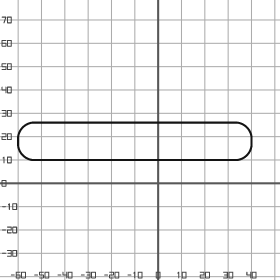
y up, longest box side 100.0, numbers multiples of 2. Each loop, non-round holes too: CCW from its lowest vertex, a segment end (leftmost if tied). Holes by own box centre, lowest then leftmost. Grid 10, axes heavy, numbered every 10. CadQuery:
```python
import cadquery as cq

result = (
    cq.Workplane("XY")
    .moveTo(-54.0, 10.0)
    .lineTo(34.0, 10.0)
    .threePointArc((38.0, 12.0), (40.0, 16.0))
    .lineTo(40.0, 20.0)
    .threePointArc((38.0, 24.0), (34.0, 26.0))
    .lineTo(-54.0, 26.0)
    .threePointArc((-58.0, 24.0), (-60.0, 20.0))
    .lineTo(-60.0, 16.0)
    .threePointArc((-58.0, 12.0), (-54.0, 10.0))
    .close()
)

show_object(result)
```